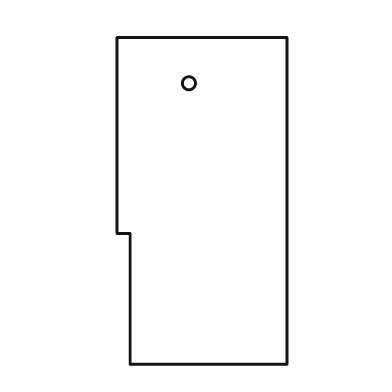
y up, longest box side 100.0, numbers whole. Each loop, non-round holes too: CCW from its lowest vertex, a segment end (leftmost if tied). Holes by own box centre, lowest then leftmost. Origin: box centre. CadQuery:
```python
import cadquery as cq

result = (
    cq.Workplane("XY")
    .moveTo(-22.0, -50.0)
    .lineTo(26.0, -50.0)
    .lineTo(26.0, 50.0)
    .lineTo(-26.0, 50.0)
    .lineTo(-26.0, -10.0)
    .lineTo(-22.0, -10.0)
    .close()
    .moveTo(-4.0, 36.0)
    .circle(2.0)
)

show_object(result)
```